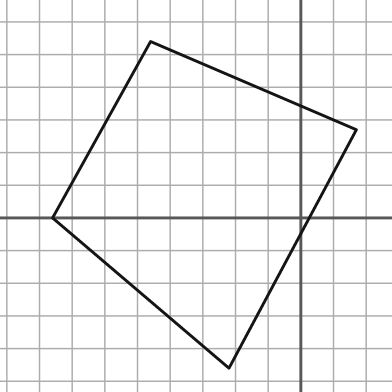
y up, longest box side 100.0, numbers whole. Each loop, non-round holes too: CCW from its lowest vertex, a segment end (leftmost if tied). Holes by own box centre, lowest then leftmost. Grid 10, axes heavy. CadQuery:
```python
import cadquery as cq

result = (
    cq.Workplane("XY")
    .moveTo(-22.0, -46.0)
    .lineTo(17.0, 27.0)
    .lineTo(-46.0, 54.0)
    .lineTo(-76.0, 0.0)
    .close()
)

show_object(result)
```